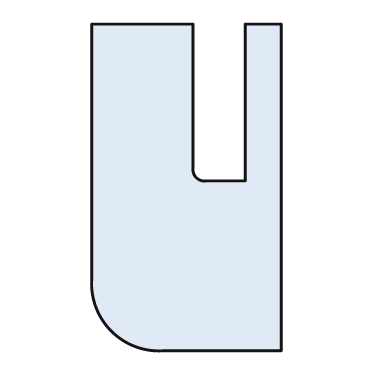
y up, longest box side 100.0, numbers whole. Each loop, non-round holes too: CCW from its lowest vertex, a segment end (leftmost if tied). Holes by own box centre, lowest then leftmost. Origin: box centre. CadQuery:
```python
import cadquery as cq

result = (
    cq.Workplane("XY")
    .moveTo(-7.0, -50.0)
    .lineTo(29.0, -50.0)
    .lineTo(29.0, 50.0)
    .lineTo(18.0, 50.0)
    .lineTo(18.0, 2.0)
    .lineTo(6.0, 2.0)
    .threePointArc((3.0, 3.0), (2.0, 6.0))
    .lineTo(2.0, 50.0)
    .lineTo(-29.0, 50.0)
    .lineTo(-29.0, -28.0)
    .threePointArc((-23.0, -44.0), (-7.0, -50.0))
    .close()
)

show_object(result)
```